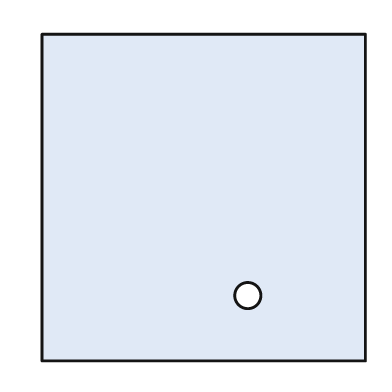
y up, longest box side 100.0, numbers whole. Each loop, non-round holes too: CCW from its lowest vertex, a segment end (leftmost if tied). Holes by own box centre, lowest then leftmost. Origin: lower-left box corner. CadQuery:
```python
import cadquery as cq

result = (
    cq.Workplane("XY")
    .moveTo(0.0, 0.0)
    .lineTo(99.0, 0.0)
    .lineTo(99.0, 100.0)
    .lineTo(0.0, 100.0)
    .close()
    .moveTo(63.0, 20.0)
    .circle(4.0)
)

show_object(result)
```